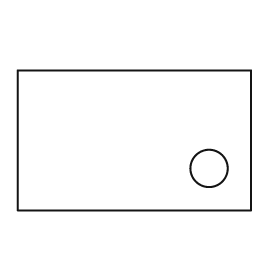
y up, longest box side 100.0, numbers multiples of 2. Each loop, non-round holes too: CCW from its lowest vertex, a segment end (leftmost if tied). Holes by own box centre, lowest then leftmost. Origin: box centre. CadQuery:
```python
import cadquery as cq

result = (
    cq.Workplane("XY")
    .moveTo(-50.0, -30.0)
    .lineTo(50.0, -30.0)
    .lineTo(50.0, 30.0)
    .lineTo(-50.0, 30.0)
    .close()
    .moveTo(32.0, -12.0)
    .circle(8.0)
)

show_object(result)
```